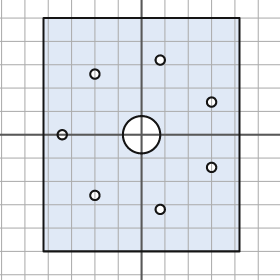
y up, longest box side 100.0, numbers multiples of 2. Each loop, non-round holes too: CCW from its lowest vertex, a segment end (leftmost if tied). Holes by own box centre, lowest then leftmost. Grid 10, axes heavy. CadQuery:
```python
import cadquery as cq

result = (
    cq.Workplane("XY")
    .moveTo(-42.0, -50.0)
    .lineTo(42.0, -50.0)
    .lineTo(42.0, 50.0)
    .lineTo(-42.0, 50.0)
    .close()
    .moveTo(8.0, -32.0)
    .circle(2.0)
    .moveTo(-20.0, -26.0)
    .circle(2.0)
    .moveTo(30.0, -14.0)
    .circle(2.0)
    .moveTo(-34.0, 0.0)
    .circle(2.0)
    .moveTo(0.0, 0.0)
    .circle(8.0)
    .moveTo(30.0, 14.0)
    .circle(2.0)
    .moveTo(-20.0, 26.0)
    .circle(2.0)
    .moveTo(8.0, 32.0)
    .circle(2.0)
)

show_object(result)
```